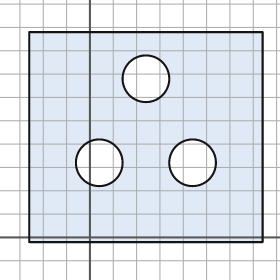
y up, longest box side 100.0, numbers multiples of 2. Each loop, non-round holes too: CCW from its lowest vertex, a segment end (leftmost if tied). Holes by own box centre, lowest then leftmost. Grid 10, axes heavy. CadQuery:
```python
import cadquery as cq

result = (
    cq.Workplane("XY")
    .moveTo(-26.0, -2.0)
    .lineTo(74.0, -2.0)
    .lineTo(74.0, 88.0)
    .lineTo(-26.0, 88.0)
    .close()
    .moveTo(4.0, 32.0)
    .circle(10.0)
    .moveTo(44.0, 32.0)
    .circle(10.0)
    .moveTo(24.0, 68.0)
    .circle(10.0)
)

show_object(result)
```